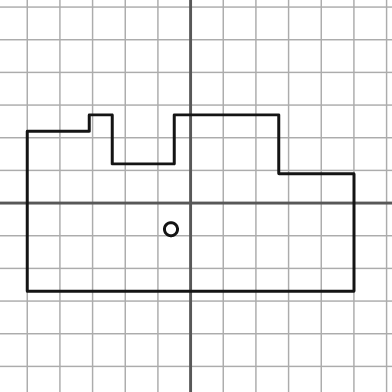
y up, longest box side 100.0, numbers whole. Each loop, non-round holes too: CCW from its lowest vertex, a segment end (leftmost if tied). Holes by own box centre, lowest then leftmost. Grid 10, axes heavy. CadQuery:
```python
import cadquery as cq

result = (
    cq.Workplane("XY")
    .moveTo(-50.0, -27.0)
    .lineTo(50.0, -27.0)
    .lineTo(50.0, 9.0)
    .lineTo(27.0, 9.0)
    .lineTo(27.0, 27.0)
    .lineTo(-5.0, 27.0)
    .lineTo(-5.0, 12.0)
    .lineTo(-24.0, 12.0)
    .lineTo(-24.0, 27.0)
    .lineTo(-31.0, 27.0)
    .lineTo(-31.0, 22.0)
    .lineTo(-50.0, 22.0)
    .close()
    .moveTo(-6.0, -8.0)
    .circle(2.0)
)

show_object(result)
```